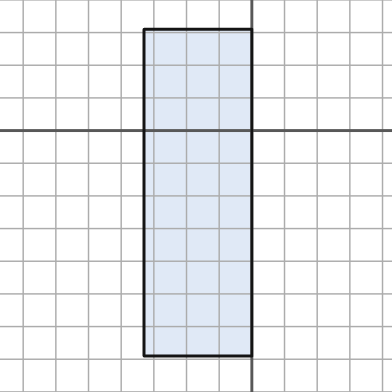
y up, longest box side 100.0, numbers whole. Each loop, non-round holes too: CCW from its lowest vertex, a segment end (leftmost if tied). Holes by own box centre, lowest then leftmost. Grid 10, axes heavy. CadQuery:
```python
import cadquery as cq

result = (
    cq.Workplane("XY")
    .moveTo(-33.0, -69.0)
    .lineTo(0.0, -69.0)
    .lineTo(0.0, 31.0)
    .lineTo(-33.0, 31.0)
    .close()
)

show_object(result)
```